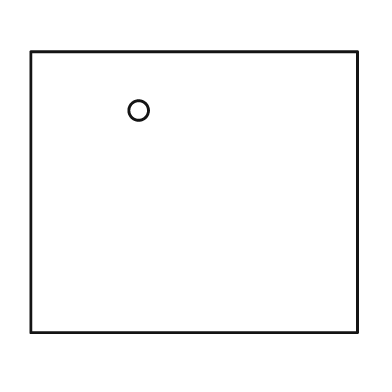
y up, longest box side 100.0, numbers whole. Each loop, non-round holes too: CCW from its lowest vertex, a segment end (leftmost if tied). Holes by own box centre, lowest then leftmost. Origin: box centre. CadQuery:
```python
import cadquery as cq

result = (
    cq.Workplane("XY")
    .moveTo(-50.0, -43.0)
    .lineTo(50.0, -43.0)
    .lineTo(50.0, 43.0)
    .lineTo(-50.0, 43.0)
    .close()
    .moveTo(-17.0, 25.0)
    .circle(3.0)
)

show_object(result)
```